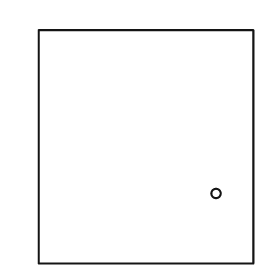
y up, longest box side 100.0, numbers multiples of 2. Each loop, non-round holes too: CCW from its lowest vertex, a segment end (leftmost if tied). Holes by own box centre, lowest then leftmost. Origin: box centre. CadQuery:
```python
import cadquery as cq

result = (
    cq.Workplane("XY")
    .moveTo(-46.0, -50.0)
    .lineTo(46.0, -50.0)
    .lineTo(46.0, 50.0)
    .lineTo(-46.0, 50.0)
    .close()
    .moveTo(30.0, -20.0)
    .circle(2.0)
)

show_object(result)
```